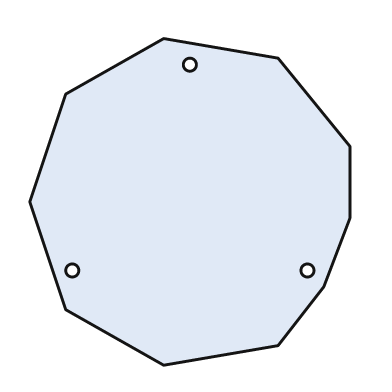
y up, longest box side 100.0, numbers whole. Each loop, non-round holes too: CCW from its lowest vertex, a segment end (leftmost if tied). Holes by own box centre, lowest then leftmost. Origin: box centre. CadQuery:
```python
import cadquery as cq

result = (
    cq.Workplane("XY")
    .moveTo(-8.0, -50.0)
    .lineTo(27.0, -44.0)
    .lineTo(41.0, -26.0)
    .lineTo(49.0, -5.0)
    .lineTo(49.0, 17.0)
    .lineTo(27.0, 44.0)
    .lineTo(-8.0, 50.0)
    .lineTo(-38.0, 33.0)
    .lineTo(-49.0, 0.0)
    .lineTo(-38.0, -33.0)
    .close()
    .moveTo(-36.0, -21.0)
    .circle(2.0)
    .moveTo(36.0, -21.0)
    .circle(2.0)
    .moveTo(0.0, 42.0)
    .circle(2.0)
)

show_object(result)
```